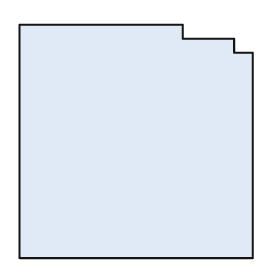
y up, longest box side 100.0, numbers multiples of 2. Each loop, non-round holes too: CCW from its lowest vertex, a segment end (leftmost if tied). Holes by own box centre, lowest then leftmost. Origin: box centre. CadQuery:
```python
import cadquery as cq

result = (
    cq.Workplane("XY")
    .moveTo(-50.0, -50.0)
    .lineTo(50.0, -50.0)
    .lineTo(50.0, 38.0)
    .lineTo(42.0, 38.0)
    .lineTo(42.0, 44.0)
    .lineTo(20.0, 44.0)
    .lineTo(20.0, 50.0)
    .lineTo(-50.0, 50.0)
    .close()
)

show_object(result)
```